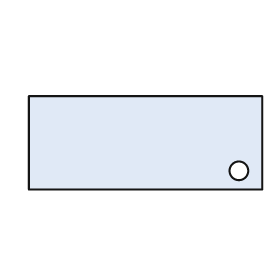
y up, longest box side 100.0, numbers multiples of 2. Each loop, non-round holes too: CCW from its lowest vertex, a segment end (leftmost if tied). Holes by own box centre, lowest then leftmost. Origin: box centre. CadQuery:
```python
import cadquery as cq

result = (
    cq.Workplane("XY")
    .moveTo(-50.0, -20.0)
    .lineTo(50.0, -20.0)
    .lineTo(50.0, 20.0)
    .lineTo(-50.0, 20.0)
    .close()
    .moveTo(40.0, -12.0)
    .circle(4.0)
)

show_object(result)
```